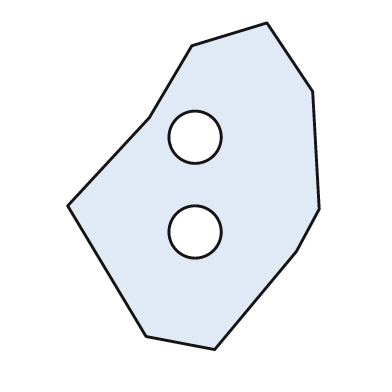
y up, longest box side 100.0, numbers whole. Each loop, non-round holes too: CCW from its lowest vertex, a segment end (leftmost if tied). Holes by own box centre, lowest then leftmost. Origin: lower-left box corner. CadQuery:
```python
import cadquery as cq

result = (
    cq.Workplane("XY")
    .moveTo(45.0, 0.0)
    .lineTo(70.0, 30.0)
    .lineTo(77.0, 43.0)
    .lineTo(75.0, 79.0)
    .lineTo(61.0, 100.0)
    .lineTo(38.0, 93.0)
    .lineTo(25.0, 71.0)
    .lineTo(0.0, 44.0)
    .lineTo(24.0, 4.0)
    .close()
    .moveTo(39.0, 36.0)
    .circle(8.0)
    .moveTo(39.0, 65.0)
    .circle(8.0)
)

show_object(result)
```